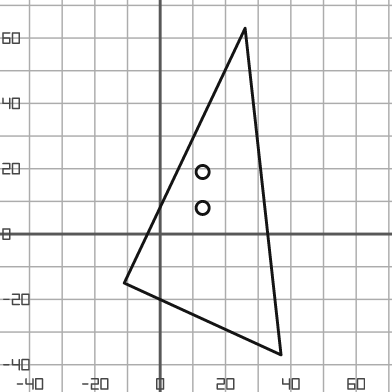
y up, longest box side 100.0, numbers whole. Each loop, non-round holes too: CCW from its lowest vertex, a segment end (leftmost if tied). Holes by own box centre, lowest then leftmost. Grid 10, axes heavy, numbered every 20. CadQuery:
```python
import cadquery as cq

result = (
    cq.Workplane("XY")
    .moveTo(37.0, -37.0)
    .lineTo(26.0, 63.0)
    .lineTo(-11.0, -15.0)
    .close()
    .moveTo(13.0, 8.0)
    .circle(2.0)
    .moveTo(13.0, 19.0)
    .circle(2.0)
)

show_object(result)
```